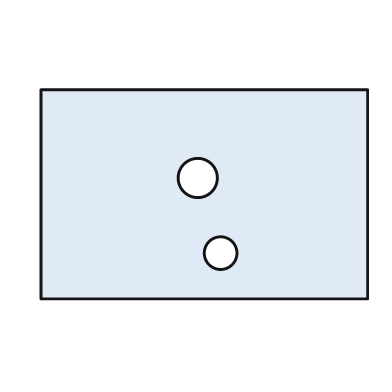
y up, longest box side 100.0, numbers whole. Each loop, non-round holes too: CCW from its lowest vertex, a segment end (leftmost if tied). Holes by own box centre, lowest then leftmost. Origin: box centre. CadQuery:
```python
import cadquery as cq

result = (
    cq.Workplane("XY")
    .moveTo(-50.0, -32.0)
    .lineTo(50.0, -32.0)
    .lineTo(50.0, 32.0)
    .lineTo(-50.0, 32.0)
    .close()
    .moveTo(5.0, -18.0)
    .circle(5.0)
    .moveTo(-2.0, 5.0)
    .circle(6.0)
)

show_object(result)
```